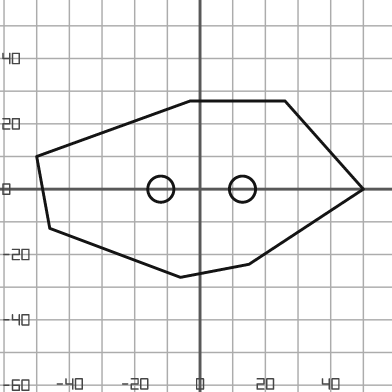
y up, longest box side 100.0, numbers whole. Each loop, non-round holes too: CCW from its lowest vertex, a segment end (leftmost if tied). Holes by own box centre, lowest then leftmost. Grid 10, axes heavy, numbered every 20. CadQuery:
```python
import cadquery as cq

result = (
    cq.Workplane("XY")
    .moveTo(-6.0, -27.0)
    .lineTo(15.0, -23.0)
    .lineTo(50.0, 0.0)
    .lineTo(26.0, 27.0)
    .lineTo(-3.0, 27.0)
    .lineTo(-50.0, 10.0)
    .lineTo(-46.0, -12.0)
    .close()
    .moveTo(-12.0, 0.0)
    .circle(4.0)
    .moveTo(13.0, 0.0)
    .circle(4.0)
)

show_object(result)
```